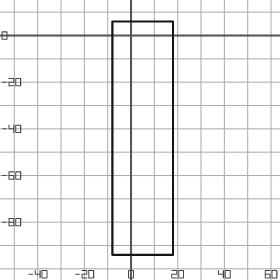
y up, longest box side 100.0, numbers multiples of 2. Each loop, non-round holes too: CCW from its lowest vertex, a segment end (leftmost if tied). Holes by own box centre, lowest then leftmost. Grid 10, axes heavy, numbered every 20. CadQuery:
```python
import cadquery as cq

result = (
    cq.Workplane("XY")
    .moveTo(-8.0, -94.0)
    .lineTo(18.0, -94.0)
    .lineTo(18.0, 6.0)
    .lineTo(-8.0, 6.0)
    .close()
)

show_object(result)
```